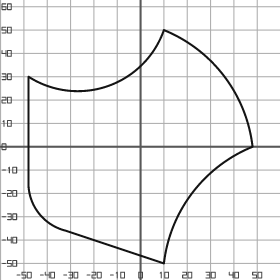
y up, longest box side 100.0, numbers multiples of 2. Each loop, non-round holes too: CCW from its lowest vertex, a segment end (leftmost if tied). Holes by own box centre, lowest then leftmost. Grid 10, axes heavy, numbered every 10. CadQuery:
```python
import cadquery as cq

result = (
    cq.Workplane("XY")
    .moveTo(10.0, -50.0)
    .threePointArc((22.0, -20.0), (48.0, 0.0))
    .threePointArc((36.0, 30.0), (10.0, 50.0))
    .threePointArc((-14.0, 26.0), (-48.0, 30.0))
    .lineTo(-48.0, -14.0)
    .threePointArc((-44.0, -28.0), (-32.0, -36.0))
    .close()
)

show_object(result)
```